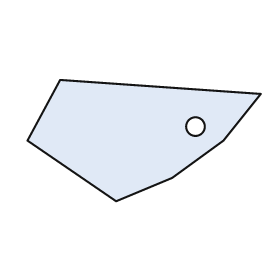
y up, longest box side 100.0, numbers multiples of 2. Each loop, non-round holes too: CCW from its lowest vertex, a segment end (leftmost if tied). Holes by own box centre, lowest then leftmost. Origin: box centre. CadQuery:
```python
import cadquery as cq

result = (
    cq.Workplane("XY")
    .moveTo(-12.0, -26.0)
    .lineTo(12.0, -16.0)
    .lineTo(34.0, 0.0)
    .lineTo(50.0, 20.0)
    .lineTo(-36.0, 26.0)
    .lineTo(-50.0, 0.0)
    .close()
    .moveTo(22.0, 6.0)
    .circle(4.0)
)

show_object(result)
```